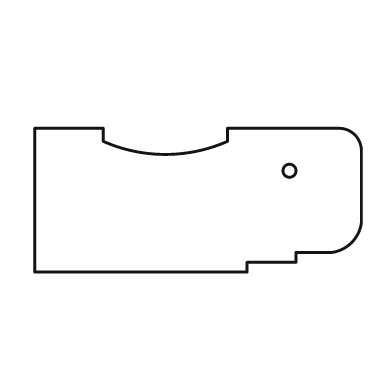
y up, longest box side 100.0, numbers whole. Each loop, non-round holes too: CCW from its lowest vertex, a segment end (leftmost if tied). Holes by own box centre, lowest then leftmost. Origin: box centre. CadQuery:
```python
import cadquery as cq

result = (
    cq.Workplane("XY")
    .moveTo(-50.0, -22.0)
    .lineTo(15.0, -22.0)
    .lineTo(15.0, -19.0)
    .lineTo(30.0, -19.0)
    .lineTo(30.0, -16.0)
    .lineTo(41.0, -16.0)
    .threePointArc((47.0, -13.0), (50.0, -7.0))
    .lineTo(50.0, 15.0)
    .threePointArc((48.0, 20.0), (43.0, 22.0))
    .lineTo(9.0, 22.0)
    .lineTo(9.0, 18.0)
    .threePointArc((-10.0, 14.0), (-29.0, 18.0))
    .lineTo(-29.0, 22.0)
    .lineTo(-50.0, 22.0)
    .close()
    .moveTo(28.0, 9.0)
    .circle(2.0)
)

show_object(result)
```